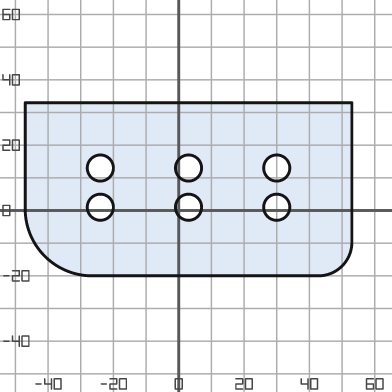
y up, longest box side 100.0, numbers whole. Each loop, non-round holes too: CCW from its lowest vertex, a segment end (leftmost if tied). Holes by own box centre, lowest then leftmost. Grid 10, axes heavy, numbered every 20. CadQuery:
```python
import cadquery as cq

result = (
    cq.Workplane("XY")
    .moveTo(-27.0, -20.0)
    .lineTo(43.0, -20.0)
    .threePointArc((50.0, -17.0), (53.0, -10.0))
    .lineTo(53.0, 33.0)
    .lineTo(-47.0, 33.0)
    .lineTo(-47.0, 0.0)
    .threePointArc((-41.0, -14.0), (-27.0, -20.0))
    .close()
    .moveTo(-24.0, 1.0)
    .circle(4.0)
    .moveTo(3.0, 1.0)
    .circle(4.0)
    .moveTo(30.0, 1.0)
    .circle(4.0)
    .moveTo(-24.0, 13.0)
    .circle(4.0)
    .moveTo(3.0, 13.0)
    .circle(4.0)
    .moveTo(30.0, 13.0)
    .circle(4.0)
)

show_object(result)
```